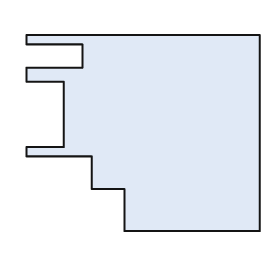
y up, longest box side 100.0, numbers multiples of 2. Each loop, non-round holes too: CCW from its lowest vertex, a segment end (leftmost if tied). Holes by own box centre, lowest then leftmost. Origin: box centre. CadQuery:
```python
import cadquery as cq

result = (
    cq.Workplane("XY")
    .moveTo(-8.0, -42.0)
    .lineTo(50.0, -42.0)
    .lineTo(50.0, 42.0)
    .lineTo(-50.0, 42.0)
    .lineTo(-50.0, 38.0)
    .lineTo(-26.0, 38.0)
    .lineTo(-26.0, 28.0)
    .lineTo(-50.0, 28.0)
    .lineTo(-50.0, 22.0)
    .lineTo(-34.0, 22.0)
    .lineTo(-34.0, -6.0)
    .lineTo(-50.0, -6.0)
    .lineTo(-50.0, -10.0)
    .lineTo(-22.0, -10.0)
    .lineTo(-22.0, -24.0)
    .lineTo(-8.0, -24.0)
    .close()
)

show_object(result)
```